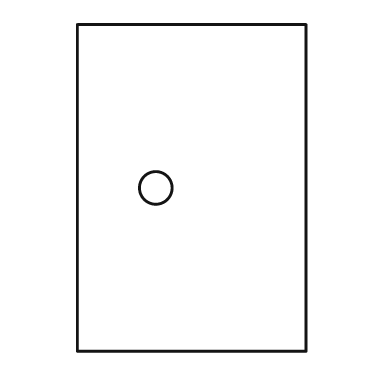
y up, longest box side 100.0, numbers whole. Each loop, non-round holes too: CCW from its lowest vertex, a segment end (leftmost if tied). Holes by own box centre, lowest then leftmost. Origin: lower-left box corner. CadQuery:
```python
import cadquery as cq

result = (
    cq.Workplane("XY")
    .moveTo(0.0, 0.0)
    .lineTo(70.0, 0.0)
    .lineTo(70.0, 100.0)
    .lineTo(0.0, 100.0)
    .close()
    .moveTo(24.0, 50.0)
    .circle(5.0)
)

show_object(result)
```